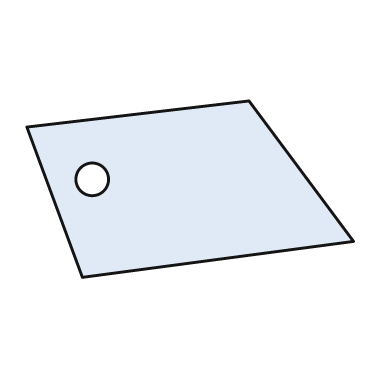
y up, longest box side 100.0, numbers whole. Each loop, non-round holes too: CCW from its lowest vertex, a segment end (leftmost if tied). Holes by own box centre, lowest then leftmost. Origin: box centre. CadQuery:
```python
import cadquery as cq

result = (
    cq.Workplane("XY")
    .moveTo(-33.0, -27.0)
    .lineTo(50.0, -16.0)
    .lineTo(18.0, 27.0)
    .lineTo(-50.0, 19.0)
    .close()
    .moveTo(-30.0, 3.0)
    .circle(5.0)
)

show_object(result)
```